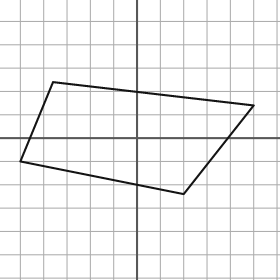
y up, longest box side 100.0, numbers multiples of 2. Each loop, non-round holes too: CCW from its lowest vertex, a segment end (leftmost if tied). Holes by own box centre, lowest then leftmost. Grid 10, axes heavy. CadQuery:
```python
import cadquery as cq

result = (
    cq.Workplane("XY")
    .moveTo(20.0, -24.0)
    .lineTo(50.0, 14.0)
    .lineTo(-36.0, 24.0)
    .lineTo(-50.0, -10.0)
    .close()
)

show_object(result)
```